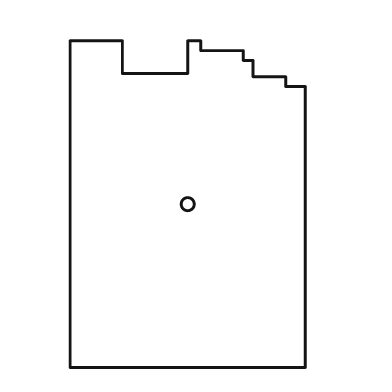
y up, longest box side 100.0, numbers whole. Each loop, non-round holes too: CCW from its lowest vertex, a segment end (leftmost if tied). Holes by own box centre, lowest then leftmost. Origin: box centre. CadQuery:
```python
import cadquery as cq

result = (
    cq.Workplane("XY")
    .moveTo(-36.0, -50.0)
    .lineTo(36.0, -50.0)
    .lineTo(36.0, 36.0)
    .lineTo(30.0, 36.0)
    .lineTo(30.0, 39.0)
    .lineTo(20.0, 39.0)
    .lineTo(20.0, 44.0)
    .lineTo(17.0, 44.0)
    .lineTo(17.0, 47.0)
    .lineTo(4.0, 47.0)
    .lineTo(4.0, 50.0)
    .lineTo(0.0, 50.0)
    .lineTo(0.0, 40.0)
    .lineTo(-20.0, 40.0)
    .lineTo(-20.0, 50.0)
    .lineTo(-36.0, 50.0)
    .close()
    .moveTo(0.0, 0.0)
    .circle(2.0)
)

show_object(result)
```